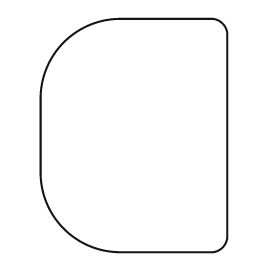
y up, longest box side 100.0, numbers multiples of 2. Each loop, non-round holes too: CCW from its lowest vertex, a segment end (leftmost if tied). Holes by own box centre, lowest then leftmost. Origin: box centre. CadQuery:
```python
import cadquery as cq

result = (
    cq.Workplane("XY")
    .moveTo(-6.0, -50.0)
    .lineTo(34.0, -50.0)
    .threePointArc((38.0, -48.0), (40.0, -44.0))
    .lineTo(40.0, 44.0)
    .threePointArc((38.0, 48.0), (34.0, 50.0))
    .lineTo(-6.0, 50.0)
    .threePointArc((-30.0, 40.0), (-40.0, 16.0))
    .lineTo(-40.0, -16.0)
    .threePointArc((-30.0, -40.0), (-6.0, -50.0))
    .close()
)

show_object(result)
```